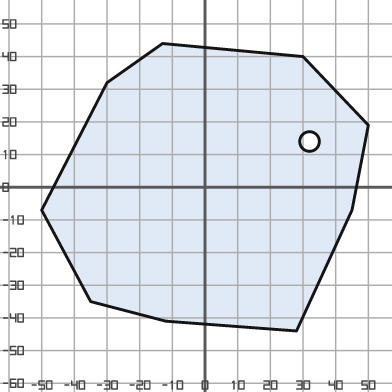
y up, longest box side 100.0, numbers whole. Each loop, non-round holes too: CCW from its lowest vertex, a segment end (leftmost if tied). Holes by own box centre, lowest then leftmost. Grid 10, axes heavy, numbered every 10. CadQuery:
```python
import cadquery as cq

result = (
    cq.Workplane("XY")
    .moveTo(28.0, -44.0)
    .lineTo(45.0, -7.0)
    .lineTo(50.0, 19.0)
    .lineTo(30.0, 40.0)
    .lineTo(-13.0, 44.0)
    .lineTo(-30.0, 32.0)
    .lineTo(-50.0, -7.0)
    .lineTo(-35.0, -35.0)
    .lineTo(-12.0, -41.0)
    .close()
    .moveTo(32.0, 14.0)
    .circle(3.0)
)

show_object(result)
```